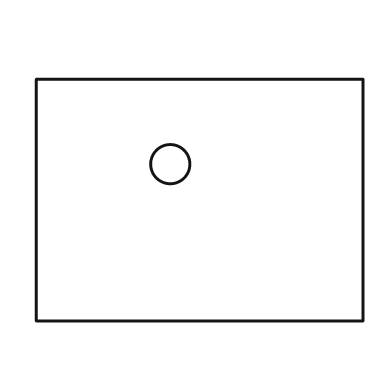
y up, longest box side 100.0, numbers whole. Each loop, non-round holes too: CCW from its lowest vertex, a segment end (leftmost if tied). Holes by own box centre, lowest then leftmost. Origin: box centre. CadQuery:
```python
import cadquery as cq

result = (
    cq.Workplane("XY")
    .moveTo(-50.0, -37.0)
    .lineTo(50.0, -37.0)
    .lineTo(50.0, 37.0)
    .lineTo(-50.0, 37.0)
    .close()
    .moveTo(-9.0, 11.0)
    .circle(6.0)
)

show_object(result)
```